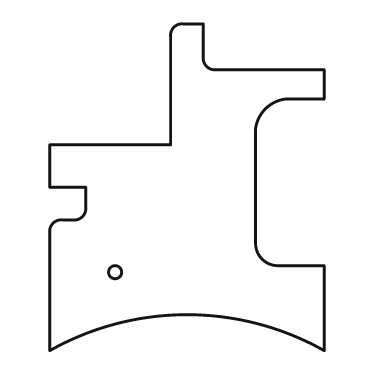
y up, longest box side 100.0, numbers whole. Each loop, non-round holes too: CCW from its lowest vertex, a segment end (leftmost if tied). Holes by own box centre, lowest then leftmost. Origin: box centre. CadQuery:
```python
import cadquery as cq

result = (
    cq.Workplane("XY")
    .moveTo(-42.0, -50.0)
    .threePointArc((0.0, -39.0), (42.0, -50.0))
    .lineTo(42.0, -24.0)
    .lineTo(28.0, -24.0)
    .threePointArc((23.0, -22.0), (21.0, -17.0))
    .lineTo(21.0, 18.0)
    .threePointArc((24.0, 24.0), (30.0, 27.0))
    .lineTo(42.0, 27.0)
    .lineTo(42.0, 36.0)
    .lineTo(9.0, 36.0)
    .threePointArc((6.0, 37.0), (5.0, 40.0))
    .lineTo(5.0, 50.0)
    .lineTo(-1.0, 50.0)
    .threePointArc((-4.0, 49.0), (-5.0, 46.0))
    .lineTo(-5.0, 13.0)
    .lineTo(-42.0, 13.0)
    .lineTo(-42.0, 0.0)
    .lineTo(-31.0, 0.0)
    .lineTo(-31.0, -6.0)
    .threePointArc((-32.0, -9.0), (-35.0, -10.0))
    .lineTo(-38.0, -10.0)
    .threePointArc((-41.0, -11.0), (-42.0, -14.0))
    .close()
    .moveTo(-22.0, -26.0)
    .circle(2.0)
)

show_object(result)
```